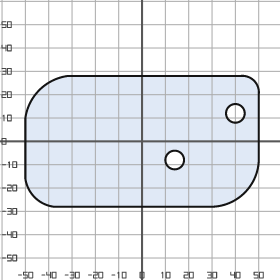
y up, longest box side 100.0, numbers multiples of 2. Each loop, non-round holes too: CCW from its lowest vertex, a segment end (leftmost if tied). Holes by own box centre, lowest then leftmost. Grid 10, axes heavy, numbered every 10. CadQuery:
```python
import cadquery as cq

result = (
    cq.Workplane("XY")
    .moveTo(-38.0, -28.0)
    .lineTo(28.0, -28.0)
    .threePointArc((44.0, -22.0), (50.0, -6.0))
    .lineTo(50.0, 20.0)
    .threePointArc((48.0, 26.0), (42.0, 28.0))
    .lineTo(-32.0, 28.0)
    .threePointArc((-44.0, 22.0), (-50.0, 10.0))
    .lineTo(-50.0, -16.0)
    .threePointArc((-46.0, -24.0), (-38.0, -28.0))
    .close()
    .moveTo(14.0, -8.0)
    .circle(4.0)
    .moveTo(40.0, 12.0)
    .circle(4.0)
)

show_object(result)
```